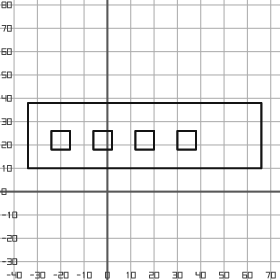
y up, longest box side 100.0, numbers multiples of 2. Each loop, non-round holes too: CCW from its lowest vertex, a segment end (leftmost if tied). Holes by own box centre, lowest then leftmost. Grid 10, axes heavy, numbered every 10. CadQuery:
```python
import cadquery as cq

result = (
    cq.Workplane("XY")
    .moveTo(-34.0, 10.0)
    .lineTo(66.0, 10.0)
    .lineTo(66.0, 38.0)
    .lineTo(-34.0, 38.0)
    .close()
    .moveTo(-24.0, 18.0)
    .lineTo(-16.0, 18.0)
    .lineTo(-16.0, 26.0)
    .lineTo(-24.0, 26.0)
    .close()
    .moveTo(-6.0, 18.0)
    .lineTo(2.0, 18.0)
    .lineTo(2.0, 26.0)
    .lineTo(-6.0, 26.0)
    .close()
    .moveTo(12.0, 18.0)
    .lineTo(20.0, 18.0)
    .lineTo(20.0, 26.0)
    .lineTo(12.0, 26.0)
    .close()
    .moveTo(30.0, 18.0)
    .lineTo(38.0, 18.0)
    .lineTo(38.0, 26.0)
    .lineTo(30.0, 26.0)
    .close()
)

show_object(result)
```